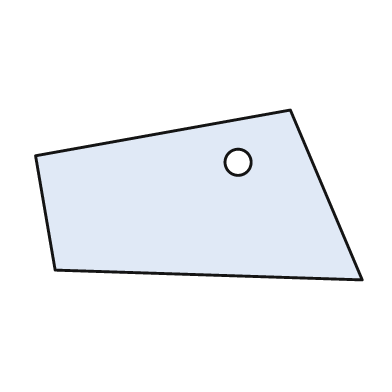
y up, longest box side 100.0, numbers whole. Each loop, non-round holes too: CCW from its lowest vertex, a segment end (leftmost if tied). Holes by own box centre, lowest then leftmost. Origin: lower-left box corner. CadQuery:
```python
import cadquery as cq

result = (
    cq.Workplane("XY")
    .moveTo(100.0, 0.0)
    .lineTo(78.0, 52.0)
    .lineTo(0.0, 38.0)
    .lineTo(6.0, 3.0)
    .close()
    .moveTo(62.0, 36.0)
    .circle(4.0)
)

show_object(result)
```